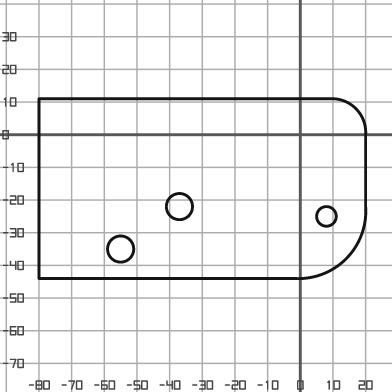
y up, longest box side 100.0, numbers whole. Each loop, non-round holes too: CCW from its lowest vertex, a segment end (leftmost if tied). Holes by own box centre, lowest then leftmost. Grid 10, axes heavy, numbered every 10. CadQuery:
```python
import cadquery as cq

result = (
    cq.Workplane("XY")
    .moveTo(-80.0, -44.0)
    .lineTo(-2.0, -44.0)
    .threePointArc((14.0, -38.0), (20.0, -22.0))
    .lineTo(20.0, 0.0)
    .threePointArc((17.0, 8.0), (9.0, 11.0))
    .lineTo(-80.0, 11.0)
    .close()
    .moveTo(-55.0, -35.0)
    .circle(4.0)
    .moveTo(8.0, -25.0)
    .circle(3.0)
    .moveTo(-37.0, -22.0)
    .circle(4.0)
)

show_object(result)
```